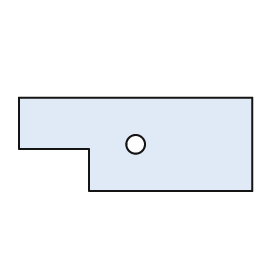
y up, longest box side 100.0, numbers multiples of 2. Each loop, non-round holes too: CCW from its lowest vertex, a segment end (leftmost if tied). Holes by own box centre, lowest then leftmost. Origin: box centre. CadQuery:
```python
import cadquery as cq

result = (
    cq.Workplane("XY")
    .moveTo(-20.0, -20.0)
    .lineTo(50.0, -20.0)
    .lineTo(50.0, 20.0)
    .lineTo(-50.0, 20.0)
    .lineTo(-50.0, -2.0)
    .lineTo(-20.0, -2.0)
    .close()
    .moveTo(0.0, 0.0)
    .circle(4.0)
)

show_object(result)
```